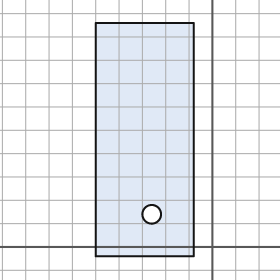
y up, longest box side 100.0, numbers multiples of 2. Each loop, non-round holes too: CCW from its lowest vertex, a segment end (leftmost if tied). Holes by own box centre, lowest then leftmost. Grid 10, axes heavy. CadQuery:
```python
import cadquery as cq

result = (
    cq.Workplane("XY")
    .moveTo(-50.0, -4.0)
    .lineTo(-8.0, -4.0)
    .lineTo(-8.0, 96.0)
    .lineTo(-50.0, 96.0)
    .close()
    .moveTo(-26.0, 14.0)
    .circle(4.0)
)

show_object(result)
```